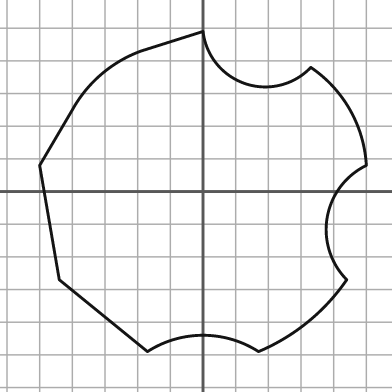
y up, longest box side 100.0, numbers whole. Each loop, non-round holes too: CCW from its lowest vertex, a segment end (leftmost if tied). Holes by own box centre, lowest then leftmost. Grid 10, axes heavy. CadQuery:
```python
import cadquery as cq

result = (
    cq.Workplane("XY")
    .moveTo(-17.0, -49.0)
    .threePointArc((0.0, -44.0), (17.0, -49.0))
    .threePointArc((32.0, -40.0), (44.0, -27.0))
    .threePointArc((38.0, -8.0), (50.0, 8.0))
    .threePointArc((45.0, 25.0), (33.0, 38.0))
    .threePointArc((13.0, 33.0), (0.0, 49.0))
    .lineTo(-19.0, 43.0)
    .threePointArc((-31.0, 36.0), (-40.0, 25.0))
    .lineTo(-50.0, 8.0)
    .lineTo(-44.0, -27.0)
    .close()
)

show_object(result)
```